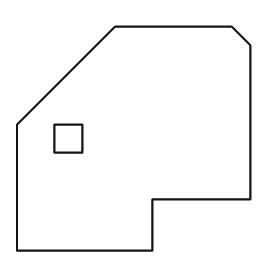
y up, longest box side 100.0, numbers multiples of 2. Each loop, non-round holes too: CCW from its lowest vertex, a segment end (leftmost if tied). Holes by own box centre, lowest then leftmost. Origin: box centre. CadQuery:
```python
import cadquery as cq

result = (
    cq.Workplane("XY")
    .moveTo(-50.0, -48.0)
    .lineTo(8.0, -48.0)
    .lineTo(8.0, -26.0)
    .lineTo(50.0, -26.0)
    .lineTo(50.0, 40.0)
    .lineTo(42.0, 48.0)
    .lineTo(-8.0, 48.0)
    .lineTo(-50.0, 6.0)
    .close()
    .moveTo(-34.0, -6.0)
    .lineTo(-22.0, -6.0)
    .lineTo(-22.0, 6.0)
    .lineTo(-34.0, 6.0)
    .close()
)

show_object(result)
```